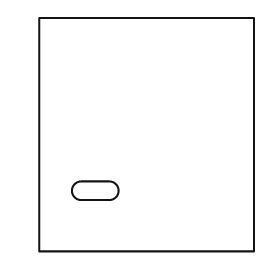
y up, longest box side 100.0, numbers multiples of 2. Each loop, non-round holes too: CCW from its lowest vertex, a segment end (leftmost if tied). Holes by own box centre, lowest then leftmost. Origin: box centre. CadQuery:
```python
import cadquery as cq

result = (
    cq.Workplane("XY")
    .moveTo(-46.0, -50.0)
    .lineTo(46.0, -50.0)
    .lineTo(46.0, 50.0)
    .lineTo(-46.0, 50.0)
    .close()
    .moveTo(-28.0, -28.0)
    .lineTo(-16.0, -28.0)
    .threePointArc((-12.0, -24.0), (-16.0, -20.0))
    .lineTo(-28.0, -20.0)
    .threePointArc((-32.0, -24.0), (-28.0, -28.0))
    .close()
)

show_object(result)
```